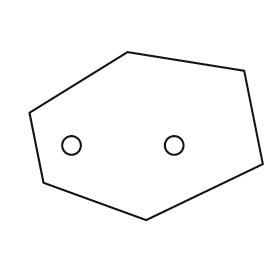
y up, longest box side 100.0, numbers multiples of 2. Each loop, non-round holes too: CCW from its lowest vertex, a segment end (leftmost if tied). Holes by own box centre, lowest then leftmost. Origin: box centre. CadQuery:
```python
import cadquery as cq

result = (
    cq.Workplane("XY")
    .moveTo(0.0, -36.0)
    .lineTo(50.0, -12.0)
    .lineTo(42.0, 28.0)
    .lineTo(-8.0, 36.0)
    .lineTo(-50.0, 10.0)
    .lineTo(-44.0, -20.0)
    .close()
    .moveTo(-32.0, -4.0)
    .circle(4.0)
    .moveTo(12.0, -4.0)
    .circle(4.0)
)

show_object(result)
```